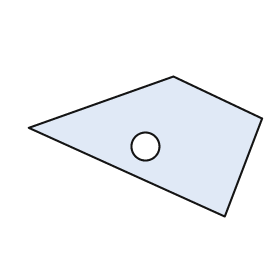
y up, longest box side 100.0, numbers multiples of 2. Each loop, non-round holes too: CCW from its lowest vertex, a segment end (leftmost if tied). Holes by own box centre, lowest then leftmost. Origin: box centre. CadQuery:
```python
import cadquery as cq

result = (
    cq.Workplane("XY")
    .moveTo(34.0, -30.0)
    .lineTo(50.0, 12.0)
    .lineTo(12.0, 30.0)
    .lineTo(-50.0, 8.0)
    .close()
    .moveTo(0.0, 0.0)
    .circle(6.0)
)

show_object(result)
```